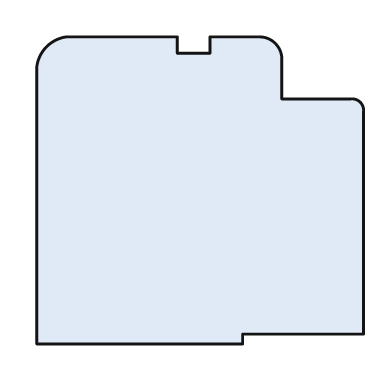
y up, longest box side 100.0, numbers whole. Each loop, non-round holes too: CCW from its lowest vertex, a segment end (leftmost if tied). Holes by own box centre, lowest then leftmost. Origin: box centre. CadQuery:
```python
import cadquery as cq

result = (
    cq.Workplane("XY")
    .moveTo(-50.0, -47.0)
    .lineTo(13.0, -47.0)
    .lineTo(13.0, -44.0)
    .lineTo(50.0, -44.0)
    .lineTo(50.0, 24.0)
    .threePointArc((49.0, 27.0), (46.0, 28.0))
    .lineTo(25.0, 28.0)
    .lineTo(25.0, 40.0)
    .threePointArc((23.0, 45.0), (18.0, 47.0))
    .lineTo(3.0, 47.0)
    .lineTo(3.0, 42.0)
    .lineTo(-7.0, 42.0)
    .lineTo(-7.0, 47.0)
    .lineTo(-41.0, 47.0)
    .threePointArc((-47.0, 44.0), (-50.0, 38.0))
    .close()
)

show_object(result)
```